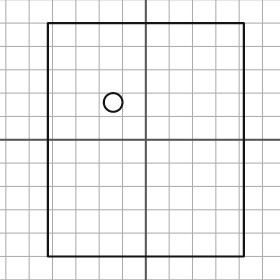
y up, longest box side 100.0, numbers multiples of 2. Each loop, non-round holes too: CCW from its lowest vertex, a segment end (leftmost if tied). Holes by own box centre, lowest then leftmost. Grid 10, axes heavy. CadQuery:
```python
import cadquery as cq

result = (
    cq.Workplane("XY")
    .moveTo(-42.0, -50.0)
    .lineTo(42.0, -50.0)
    .lineTo(42.0, 50.0)
    .lineTo(-42.0, 50.0)
    .close()
    .moveTo(-14.0, 16.0)
    .circle(4.0)
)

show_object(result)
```